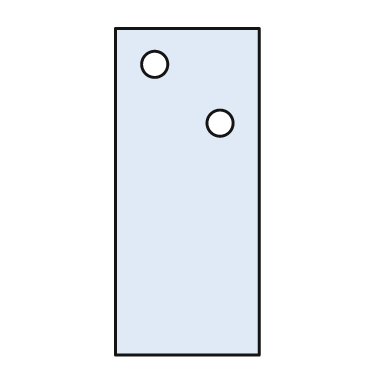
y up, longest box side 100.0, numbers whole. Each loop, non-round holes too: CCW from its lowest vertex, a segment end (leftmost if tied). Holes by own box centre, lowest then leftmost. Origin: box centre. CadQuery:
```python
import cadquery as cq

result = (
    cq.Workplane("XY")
    .moveTo(-22.0, -50.0)
    .lineTo(22.0, -50.0)
    .lineTo(22.0, 50.0)
    .lineTo(-22.0, 50.0)
    .close()
    .moveTo(10.0, 21.0)
    .circle(4.0)
    .moveTo(-10.0, 39.0)
    .circle(4.0)
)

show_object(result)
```